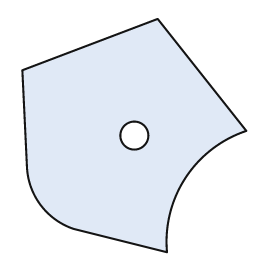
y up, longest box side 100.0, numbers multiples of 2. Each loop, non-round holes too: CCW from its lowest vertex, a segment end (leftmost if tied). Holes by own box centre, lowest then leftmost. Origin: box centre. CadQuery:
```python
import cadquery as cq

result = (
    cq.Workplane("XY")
    .moveTo(14.0, -50.0)
    .threePointArc((22.0, -18.0), (48.0, 2.0))
    .lineTo(10.0, 50.0)
    .lineTo(-48.0, 28.0)
    .lineTo(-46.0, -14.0)
    .threePointArc((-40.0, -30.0), (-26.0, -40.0))
    .close()
    .moveTo(0.0, 0.0)
    .circle(6.0)
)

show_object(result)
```